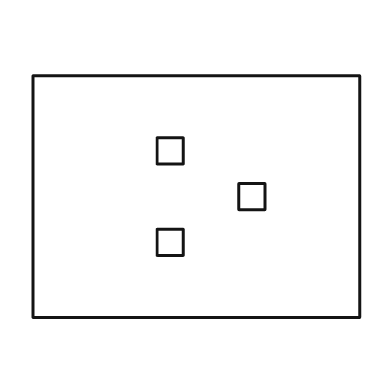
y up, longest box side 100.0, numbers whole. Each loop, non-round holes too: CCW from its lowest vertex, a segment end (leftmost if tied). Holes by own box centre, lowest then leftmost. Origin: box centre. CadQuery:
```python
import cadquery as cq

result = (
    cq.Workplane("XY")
    .moveTo(-50.0, -37.0)
    .lineTo(50.0, -37.0)
    .lineTo(50.0, 37.0)
    .lineTo(-50.0, 37.0)
    .close()
    .moveTo(-12.0, -18.0)
    .lineTo(-4.0, -18.0)
    .lineTo(-4.0, -10.0)
    .lineTo(-12.0, -10.0)
    .close()
    .moveTo(13.0, -4.0)
    .lineTo(21.0, -4.0)
    .lineTo(21.0, 4.0)
    .lineTo(13.0, 4.0)
    .close()
    .moveTo(-12.0, 10.0)
    .lineTo(-4.0, 10.0)
    .lineTo(-4.0, 18.0)
    .lineTo(-12.0, 18.0)
    .close()
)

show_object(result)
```